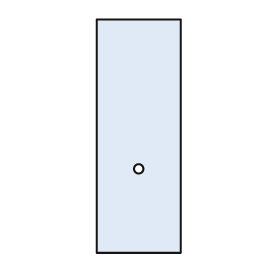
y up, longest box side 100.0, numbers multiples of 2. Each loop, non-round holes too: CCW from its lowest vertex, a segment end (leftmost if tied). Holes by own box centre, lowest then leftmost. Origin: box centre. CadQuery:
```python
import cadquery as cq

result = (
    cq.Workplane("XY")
    .moveTo(-18.0, -50.0)
    .lineTo(18.0, -50.0)
    .lineTo(18.0, 50.0)
    .lineTo(-18.0, 50.0)
    .close()
    .moveTo(0.0, -14.0)
    .circle(2.0)
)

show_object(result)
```